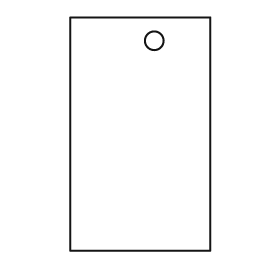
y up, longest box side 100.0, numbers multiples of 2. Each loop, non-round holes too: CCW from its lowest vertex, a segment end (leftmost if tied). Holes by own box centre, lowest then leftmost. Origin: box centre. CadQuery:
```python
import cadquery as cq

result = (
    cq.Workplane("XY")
    .moveTo(-30.0, -50.0)
    .lineTo(30.0, -50.0)
    .lineTo(30.0, 50.0)
    .lineTo(-30.0, 50.0)
    .close()
    .moveTo(6.0, 40.0)
    .circle(4.0)
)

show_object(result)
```